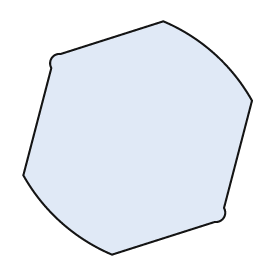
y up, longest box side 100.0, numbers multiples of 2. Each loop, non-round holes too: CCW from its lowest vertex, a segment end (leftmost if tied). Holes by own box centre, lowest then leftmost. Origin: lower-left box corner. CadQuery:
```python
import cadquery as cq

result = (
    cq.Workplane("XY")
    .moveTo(38.0, 0.0)
    .lineTo(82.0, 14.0)
    .threePointArc((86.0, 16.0), (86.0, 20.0))
    .lineTo(98.0, 66.0)
    .threePointArc((82.0, 86.0), (60.0, 100.0))
    .lineTo(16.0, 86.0)
    .threePointArc((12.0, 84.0), (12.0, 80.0))
    .lineTo(0.0, 34.0)
    .threePointArc((16.0, 14.0), (38.0, 0.0))
    .close()
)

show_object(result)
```